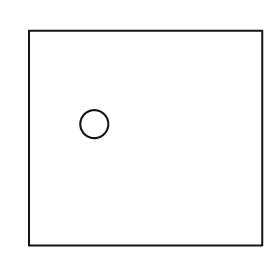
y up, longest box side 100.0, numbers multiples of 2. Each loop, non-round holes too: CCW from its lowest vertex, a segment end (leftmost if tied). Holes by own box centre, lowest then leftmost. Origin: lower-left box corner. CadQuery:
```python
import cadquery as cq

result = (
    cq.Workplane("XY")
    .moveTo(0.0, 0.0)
    .lineTo(100.0, 0.0)
    .lineTo(100.0, 92.0)
    .lineTo(0.0, 92.0)
    .close()
    .moveTo(28.0, 52.0)
    .circle(6.0)
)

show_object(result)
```